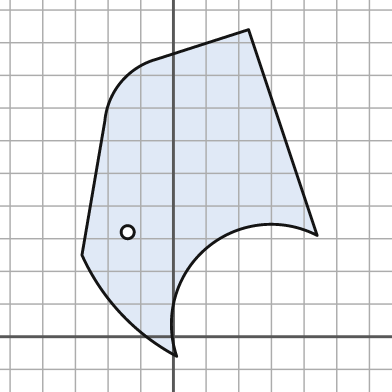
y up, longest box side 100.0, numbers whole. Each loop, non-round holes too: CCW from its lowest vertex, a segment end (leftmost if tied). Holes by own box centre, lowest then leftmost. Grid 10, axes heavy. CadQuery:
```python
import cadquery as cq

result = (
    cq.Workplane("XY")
    .moveTo(1.0, -6.0)
    .threePointArc((10.0, 27.0), (44.0, 31.0))
    .lineTo(23.0, 94.0)
    .lineTo(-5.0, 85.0)
    .threePointArc((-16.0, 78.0), (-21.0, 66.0))
    .lineTo(-28.0, 25.0)
    .threePointArc((-16.0, 7.0), (1.0, -6.0))
    .close()
    .moveTo(-14.0, 32.0)
    .circle(2.0)
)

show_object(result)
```